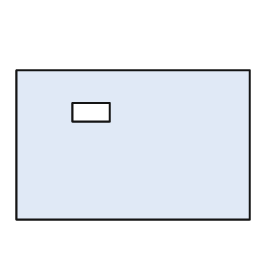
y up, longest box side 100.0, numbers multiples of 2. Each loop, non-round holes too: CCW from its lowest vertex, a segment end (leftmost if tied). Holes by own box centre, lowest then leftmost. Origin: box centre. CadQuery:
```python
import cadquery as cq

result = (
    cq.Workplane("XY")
    .moveTo(-50.0, -32.0)
    .lineTo(50.0, -32.0)
    .lineTo(50.0, 32.0)
    .lineTo(-50.0, 32.0)
    .close()
    .moveTo(-26.0, 10.0)
    .lineTo(-10.0, 10.0)
    .lineTo(-10.0, 18.0)
    .lineTo(-26.0, 18.0)
    .close()
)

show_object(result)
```